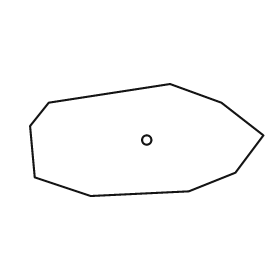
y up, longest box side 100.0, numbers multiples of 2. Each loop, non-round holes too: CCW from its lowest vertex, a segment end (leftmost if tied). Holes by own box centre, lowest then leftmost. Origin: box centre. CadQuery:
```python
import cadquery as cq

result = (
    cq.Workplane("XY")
    .moveTo(-24.0, -24.0)
    .lineTo(18.0, -22.0)
    .lineTo(38.0, -14.0)
    .lineTo(50.0, 2.0)
    .lineTo(32.0, 16.0)
    .lineTo(10.0, 24.0)
    .lineTo(-42.0, 16.0)
    .lineTo(-50.0, 6.0)
    .lineTo(-48.0, -16.0)
    .close()
    .moveTo(0.0, 0.0)
    .circle(2.0)
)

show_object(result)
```